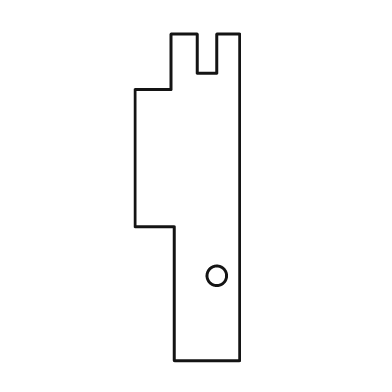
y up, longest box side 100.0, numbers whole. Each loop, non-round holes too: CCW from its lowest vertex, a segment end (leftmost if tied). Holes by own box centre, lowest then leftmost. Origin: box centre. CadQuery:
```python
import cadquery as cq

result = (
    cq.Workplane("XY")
    .moveTo(-4.0, -50.0)
    .lineTo(16.0, -50.0)
    .lineTo(16.0, 50.0)
    .lineTo(9.0, 50.0)
    .lineTo(9.0, 38.0)
    .lineTo(3.0, 38.0)
    .lineTo(3.0, 50.0)
    .lineTo(-5.0, 50.0)
    .lineTo(-5.0, 33.0)
    .lineTo(-16.0, 33.0)
    .lineTo(-16.0, -9.0)
    .lineTo(-4.0, -9.0)
    .close()
    .moveTo(9.0, -24.0)
    .circle(3.0)
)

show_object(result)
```